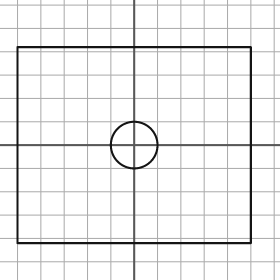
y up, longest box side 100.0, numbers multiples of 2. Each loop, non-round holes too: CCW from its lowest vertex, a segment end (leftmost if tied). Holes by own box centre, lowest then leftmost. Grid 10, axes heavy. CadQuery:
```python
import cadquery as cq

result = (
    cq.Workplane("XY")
    .moveTo(-50.0, -42.0)
    .lineTo(50.0, -42.0)
    .lineTo(50.0, 42.0)
    .lineTo(-50.0, 42.0)
    .close()
    .moveTo(0.0, 0.0)
    .circle(10.0)
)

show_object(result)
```